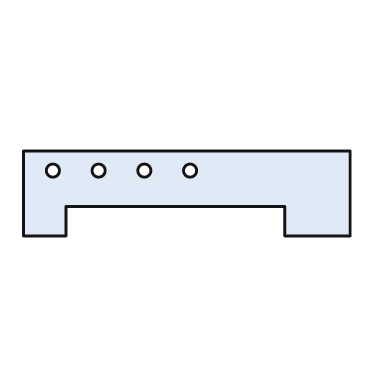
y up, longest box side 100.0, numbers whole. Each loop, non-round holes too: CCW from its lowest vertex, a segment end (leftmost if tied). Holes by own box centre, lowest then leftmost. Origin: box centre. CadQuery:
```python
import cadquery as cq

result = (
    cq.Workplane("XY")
    .moveTo(-50.0, -13.0)
    .lineTo(-37.0, -13.0)
    .lineTo(-37.0, -4.0)
    .lineTo(30.0, -4.0)
    .lineTo(30.0, -13.0)
    .lineTo(50.0, -13.0)
    .lineTo(50.0, 13.0)
    .lineTo(-50.0, 13.0)
    .close()
    .moveTo(-41.0, 7.0)
    .circle(2.0)
    .moveTo(-27.0, 7.0)
    .circle(2.0)
    .moveTo(-13.0, 7.0)
    .circle(2.0)
    .moveTo(1.0, 7.0)
    .circle(2.0)
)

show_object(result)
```